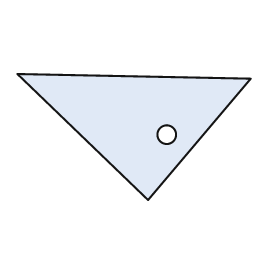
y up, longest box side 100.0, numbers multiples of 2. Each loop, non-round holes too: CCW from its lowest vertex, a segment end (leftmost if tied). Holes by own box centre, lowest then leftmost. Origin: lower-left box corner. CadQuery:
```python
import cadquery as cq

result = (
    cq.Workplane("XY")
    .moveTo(56.0, 0.0)
    .lineTo(100.0, 52.0)
    .lineTo(0.0, 54.0)
    .close()
    .moveTo(64.0, 28.0)
    .circle(4.0)
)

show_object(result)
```